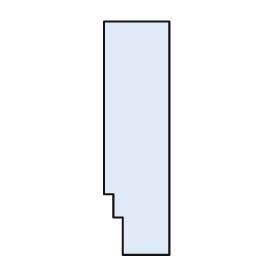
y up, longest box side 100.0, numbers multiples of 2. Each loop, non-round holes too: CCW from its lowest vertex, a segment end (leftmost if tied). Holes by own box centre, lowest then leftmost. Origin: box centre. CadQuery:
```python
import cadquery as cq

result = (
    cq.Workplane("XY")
    .moveTo(-6.0, -50.0)
    .lineTo(14.0, -50.0)
    .lineTo(14.0, 50.0)
    .lineTo(-14.0, 50.0)
    .lineTo(-14.0, -24.0)
    .lineTo(-10.0, -24.0)
    .lineTo(-10.0, -34.0)
    .lineTo(-6.0, -34.0)
    .close()
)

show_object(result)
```